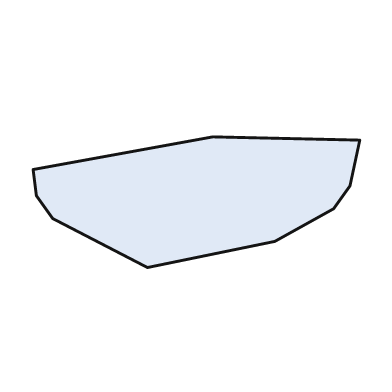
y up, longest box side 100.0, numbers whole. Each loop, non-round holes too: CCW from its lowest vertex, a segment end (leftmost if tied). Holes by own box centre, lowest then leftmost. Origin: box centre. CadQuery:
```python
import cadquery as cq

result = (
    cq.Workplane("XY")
    .moveTo(-15.0, -20.0)
    .lineTo(24.0, -12.0)
    .lineTo(42.0, -2.0)
    .lineTo(47.0, 5.0)
    .lineTo(50.0, 19.0)
    .lineTo(5.0, 20.0)
    .lineTo(-50.0, 10.0)
    .lineTo(-49.0, 2.0)
    .lineTo(-44.0, -5.0)
    .close()
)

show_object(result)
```